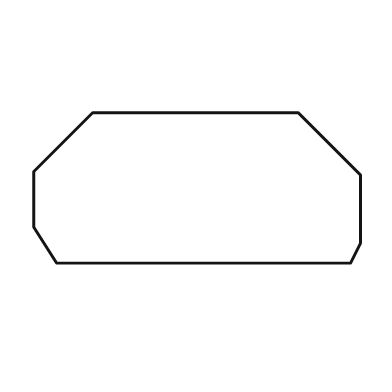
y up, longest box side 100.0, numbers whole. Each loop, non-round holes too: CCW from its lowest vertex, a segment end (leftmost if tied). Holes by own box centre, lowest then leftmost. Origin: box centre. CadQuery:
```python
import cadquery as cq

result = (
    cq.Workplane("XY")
    .moveTo(-43.0, -23.0)
    .lineTo(47.0, -23.0)
    .lineTo(50.0, -17.0)
    .lineTo(50.0, 4.0)
    .lineTo(31.0, 23.0)
    .lineTo(-32.0, 23.0)
    .lineTo(-50.0, 5.0)
    .lineTo(-50.0, -12.0)
    .close()
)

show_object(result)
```